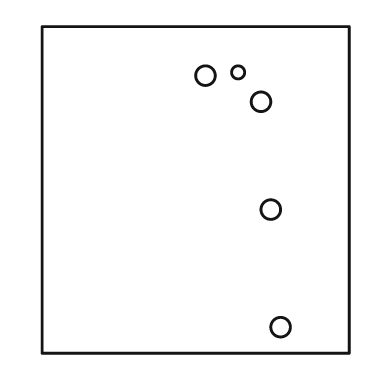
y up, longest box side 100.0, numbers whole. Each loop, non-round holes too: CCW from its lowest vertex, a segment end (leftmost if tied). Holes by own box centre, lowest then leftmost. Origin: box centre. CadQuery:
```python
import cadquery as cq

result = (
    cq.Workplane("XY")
    .moveTo(-47.0, -50.0)
    .lineTo(47.0, -50.0)
    .lineTo(47.0, 50.0)
    .lineTo(-47.0, 50.0)
    .close()
    .moveTo(26.0, -42.0)
    .circle(3.0)
    .moveTo(23.0, -6.0)
    .circle(3.0)
    .moveTo(20.0, 27.0)
    .circle(3.0)
    .moveTo(3.0, 35.0)
    .circle(3.0)
    .moveTo(13.0, 36.0)
    .circle(2.0)
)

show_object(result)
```